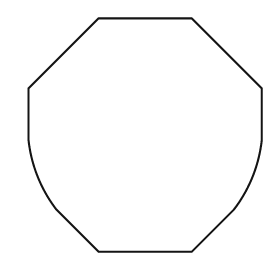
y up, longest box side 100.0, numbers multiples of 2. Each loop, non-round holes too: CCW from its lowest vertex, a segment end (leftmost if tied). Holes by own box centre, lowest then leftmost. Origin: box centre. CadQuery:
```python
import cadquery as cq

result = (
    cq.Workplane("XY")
    .moveTo(-20.0, -50.0)
    .lineTo(20.0, -50.0)
    .lineTo(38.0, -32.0)
    .threePointArc((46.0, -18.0), (50.0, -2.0))
    .lineTo(50.0, 20.0)
    .lineTo(20.0, 50.0)
    .lineTo(-20.0, 50.0)
    .lineTo(-50.0, 20.0)
    .lineTo(-50.0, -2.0)
    .threePointArc((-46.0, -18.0), (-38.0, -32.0))
    .close()
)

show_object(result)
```